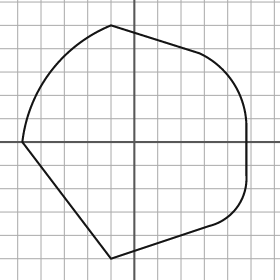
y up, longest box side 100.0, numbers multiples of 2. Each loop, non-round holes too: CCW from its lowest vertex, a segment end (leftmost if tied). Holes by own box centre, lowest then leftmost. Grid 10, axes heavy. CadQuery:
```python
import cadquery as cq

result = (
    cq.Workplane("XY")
    .moveTo(-10.0, -50.0)
    .lineTo(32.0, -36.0)
    .threePointArc((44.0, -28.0), (48.0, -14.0))
    .lineTo(48.0, 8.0)
    .threePointArc((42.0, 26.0), (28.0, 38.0))
    .lineTo(-10.0, 50.0)
    .threePointArc((-36.0, 30.0), (-48.0, 0.0))
    .close()
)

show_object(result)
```